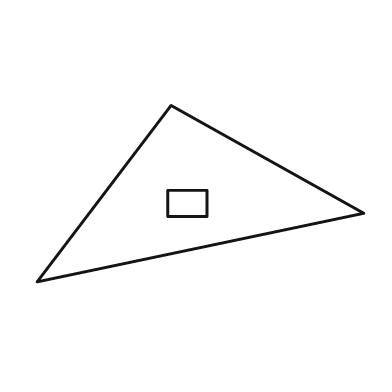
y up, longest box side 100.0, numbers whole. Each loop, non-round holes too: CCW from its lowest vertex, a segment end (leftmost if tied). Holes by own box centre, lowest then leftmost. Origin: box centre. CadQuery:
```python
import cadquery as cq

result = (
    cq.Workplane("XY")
    .moveTo(-50.0, -27.0)
    .lineTo(50.0, -6.0)
    .lineTo(-9.0, 27.0)
    .close()
    .moveTo(-10.0, -7.0)
    .lineTo(2.0, -7.0)
    .lineTo(2.0, 1.0)
    .lineTo(-10.0, 1.0)
    .close()
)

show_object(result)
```